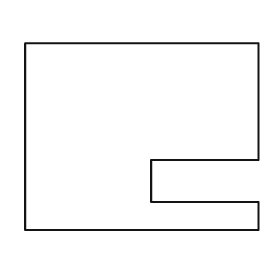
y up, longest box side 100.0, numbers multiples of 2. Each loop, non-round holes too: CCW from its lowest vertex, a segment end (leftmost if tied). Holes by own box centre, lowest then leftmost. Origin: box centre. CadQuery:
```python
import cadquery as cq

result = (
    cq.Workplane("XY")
    .moveTo(-50.0, -40.0)
    .lineTo(50.0, -40.0)
    .lineTo(50.0, -28.0)
    .lineTo(4.0, -28.0)
    .lineTo(4.0, -10.0)
    .lineTo(50.0, -10.0)
    .lineTo(50.0, 40.0)
    .lineTo(-50.0, 40.0)
    .close()
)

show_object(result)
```